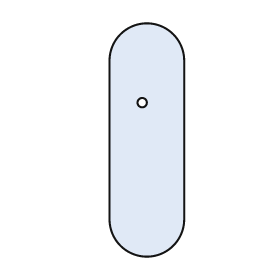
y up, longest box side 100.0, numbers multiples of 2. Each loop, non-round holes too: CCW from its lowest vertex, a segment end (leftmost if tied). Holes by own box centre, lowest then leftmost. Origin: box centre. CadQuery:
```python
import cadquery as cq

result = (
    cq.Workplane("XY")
    .moveTo(-16.0, -34.0)
    .threePointArc((0.0, -50.0), (16.0, -34.0))
    .lineTo(16.0, 34.0)
    .threePointArc((0.0, 50.0), (-16.0, 34.0))
    .close()
    .moveTo(-2.0, 16.0)
    .circle(2.0)
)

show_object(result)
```